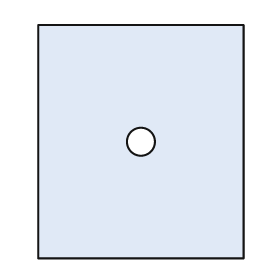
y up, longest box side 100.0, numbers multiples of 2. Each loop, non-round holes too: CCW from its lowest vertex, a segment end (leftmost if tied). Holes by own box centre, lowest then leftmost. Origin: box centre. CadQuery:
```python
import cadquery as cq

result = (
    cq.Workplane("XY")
    .moveTo(-44.0, -50.0)
    .lineTo(44.0, -50.0)
    .lineTo(44.0, 50.0)
    .lineTo(-44.0, 50.0)
    .close()
    .moveTo(0.0, 0.0)
    .circle(6.0)
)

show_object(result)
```